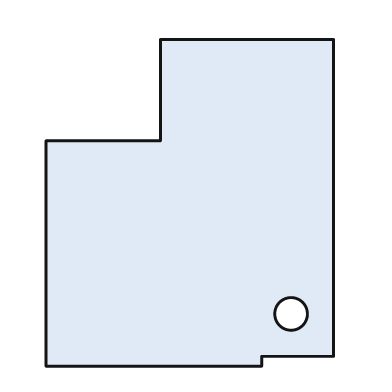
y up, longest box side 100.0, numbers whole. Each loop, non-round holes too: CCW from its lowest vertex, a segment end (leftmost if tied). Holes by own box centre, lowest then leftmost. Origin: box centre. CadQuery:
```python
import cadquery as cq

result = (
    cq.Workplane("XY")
    .moveTo(-44.0, -50.0)
    .lineTo(22.0, -50.0)
    .lineTo(22.0, -47.0)
    .lineTo(44.0, -47.0)
    .lineTo(44.0, 50.0)
    .lineTo(-9.0, 50.0)
    .lineTo(-9.0, 19.0)
    .lineTo(-44.0, 19.0)
    .close()
    .moveTo(31.0, -34.0)
    .circle(5.0)
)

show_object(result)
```